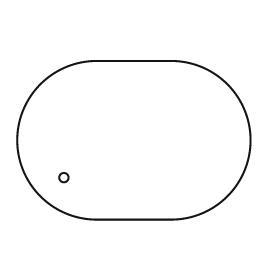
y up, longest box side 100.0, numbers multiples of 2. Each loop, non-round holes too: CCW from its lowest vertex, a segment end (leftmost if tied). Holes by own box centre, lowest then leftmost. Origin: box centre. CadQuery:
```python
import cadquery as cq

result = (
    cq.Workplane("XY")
    .moveTo(-16.0, -34.0)
    .lineTo(16.0, -34.0)
    .threePointArc((50.0, 0.0), (16.0, 34.0))
    .lineTo(-16.0, 34.0)
    .threePointArc((-50.0, 0.0), (-16.0, -34.0))
    .close()
    .moveTo(-30.0, -16.0)
    .circle(2.0)
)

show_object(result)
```